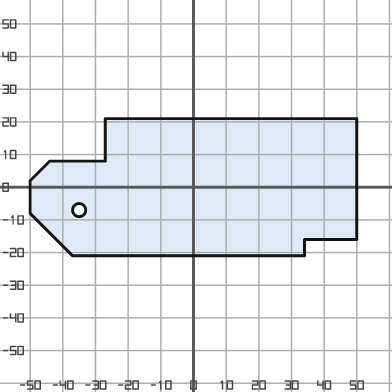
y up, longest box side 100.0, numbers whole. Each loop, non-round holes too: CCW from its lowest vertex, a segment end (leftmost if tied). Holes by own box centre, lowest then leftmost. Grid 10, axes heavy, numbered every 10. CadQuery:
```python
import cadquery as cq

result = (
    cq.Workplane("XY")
    .moveTo(-37.0, -21.0)
    .lineTo(34.0, -21.0)
    .lineTo(34.0, -16.0)
    .lineTo(50.0, -16.0)
    .lineTo(50.0, 21.0)
    .lineTo(-27.0, 21.0)
    .lineTo(-27.0, 8.0)
    .lineTo(-44.0, 8.0)
    .lineTo(-50.0, 2.0)
    .lineTo(-50.0, -8.0)
    .close()
    .moveTo(-35.0, -7.0)
    .circle(2.0)
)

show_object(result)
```